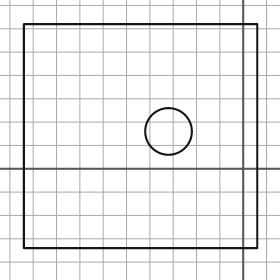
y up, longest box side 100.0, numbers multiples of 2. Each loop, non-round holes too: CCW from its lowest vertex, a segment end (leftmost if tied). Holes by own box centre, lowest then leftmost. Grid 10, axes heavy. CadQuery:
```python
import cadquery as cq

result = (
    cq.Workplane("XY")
    .moveTo(-94.0, -34.0)
    .lineTo(6.0, -34.0)
    .lineTo(6.0, 62.0)
    .lineTo(-94.0, 62.0)
    .close()
    .moveTo(-32.0, 16.0)
    .circle(10.0)
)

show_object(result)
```